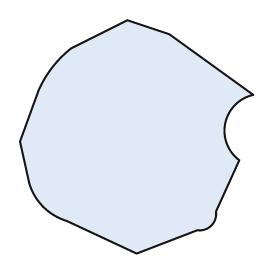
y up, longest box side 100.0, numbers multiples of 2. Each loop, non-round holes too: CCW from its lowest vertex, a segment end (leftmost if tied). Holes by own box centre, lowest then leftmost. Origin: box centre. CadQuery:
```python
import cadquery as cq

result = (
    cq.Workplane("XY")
    .moveTo(0.0, -50.0)
    .lineTo(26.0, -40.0)
    .threePointArc((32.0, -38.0), (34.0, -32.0))
    .lineTo(44.0, -10.0)
    .threePointArc((38.0, 6.0), (50.0, 18.0))
    .lineTo(14.0, 44.0)
    .lineTo(-4.0, 50.0)
    .lineTo(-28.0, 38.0)
    .threePointArc((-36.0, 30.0), (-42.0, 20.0))
    .lineTo(-50.0, -2.0)
    .lineTo(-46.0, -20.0)
    .threePointArc((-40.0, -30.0), (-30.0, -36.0))
    .close()
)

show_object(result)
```